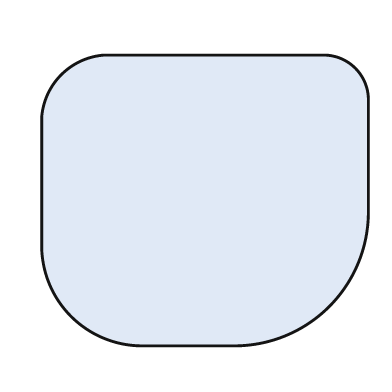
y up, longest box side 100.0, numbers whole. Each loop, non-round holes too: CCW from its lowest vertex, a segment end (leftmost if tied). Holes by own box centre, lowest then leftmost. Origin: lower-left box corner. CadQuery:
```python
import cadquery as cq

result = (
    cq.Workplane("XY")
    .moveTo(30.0, 0.0)
    .lineTo(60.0, 0.0)
    .threePointArc((88.0, 12.0), (100.0, 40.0))
    .lineTo(100.0, 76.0)
    .threePointArc((96.0, 85.0), (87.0, 89.0))
    .lineTo(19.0, 89.0)
    .threePointArc((6.0, 83.0), (0.0, 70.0))
    .lineTo(0.0, 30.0)
    .threePointArc((9.0, 9.0), (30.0, 0.0))
    .close()
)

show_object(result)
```